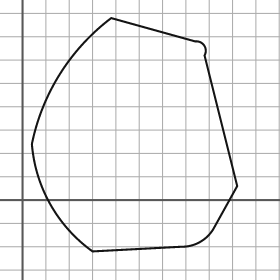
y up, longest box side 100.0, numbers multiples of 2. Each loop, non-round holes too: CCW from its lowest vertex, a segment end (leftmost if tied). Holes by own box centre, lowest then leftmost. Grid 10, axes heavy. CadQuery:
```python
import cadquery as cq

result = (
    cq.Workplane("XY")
    .moveTo(30.0, -22.0)
    .lineTo(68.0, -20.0)
    .threePointArc((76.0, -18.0), (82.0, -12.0))
    .lineTo(92.0, 6.0)
    .lineTo(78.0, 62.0)
    .threePointArc((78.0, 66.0), (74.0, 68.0))
    .lineTo(38.0, 78.0)
    .threePointArc((16.0, 54.0), (4.0, 24.0))
    .threePointArc((12.0, -2.0), (30.0, -22.0))
    .close()
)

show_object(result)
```